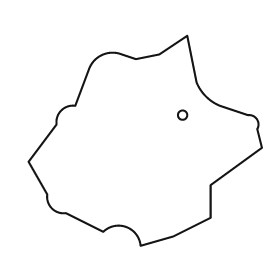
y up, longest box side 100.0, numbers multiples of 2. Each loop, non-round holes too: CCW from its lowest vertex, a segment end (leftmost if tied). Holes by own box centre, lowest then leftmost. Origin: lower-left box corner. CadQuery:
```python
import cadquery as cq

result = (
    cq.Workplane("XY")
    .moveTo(48.0, 0.0)
    .lineTo(62.0, 4.0)
    .lineTo(78.0, 12.0)
    .lineTo(78.0, 26.0)
    .lineTo(100.0, 42.0)
    .lineTo(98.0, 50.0)
    .threePointArc((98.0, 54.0), (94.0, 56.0))
    .lineTo(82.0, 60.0)
    .threePointArc((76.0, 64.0), (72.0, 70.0))
    .lineTo(68.0, 90.0)
    .lineTo(56.0, 82.0)
    .lineTo(46.0, 80.0)
    .lineTo(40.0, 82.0)
    .threePointArc((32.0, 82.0), (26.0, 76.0))
    .lineTo(20.0, 60.0)
    .threePointArc((14.0, 58.0), (12.0, 52.0))
    .lineTo(0.0, 36.0)
    .lineTo(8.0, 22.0)
    .threePointArc((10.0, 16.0), (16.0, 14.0))
    .lineTo(32.0, 6.0)
    .threePointArc((42.0, 8.0), (48.0, 0.0))
    .close()
    .moveTo(66.0, 56.0)
    .circle(2.0)
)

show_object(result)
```